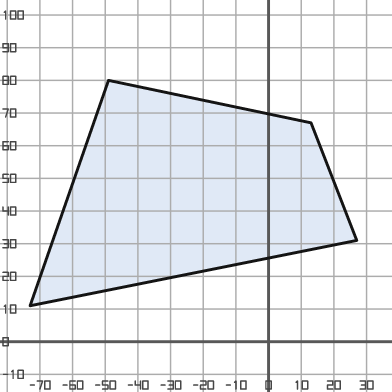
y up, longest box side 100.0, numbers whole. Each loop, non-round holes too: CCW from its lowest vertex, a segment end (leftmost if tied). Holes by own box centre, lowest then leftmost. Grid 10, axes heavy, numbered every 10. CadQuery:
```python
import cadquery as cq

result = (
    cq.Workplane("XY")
    .moveTo(-73.0, 11.0)
    .lineTo(27.0, 31.0)
    .lineTo(13.0, 67.0)
    .lineTo(-49.0, 80.0)
    .close()
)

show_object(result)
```